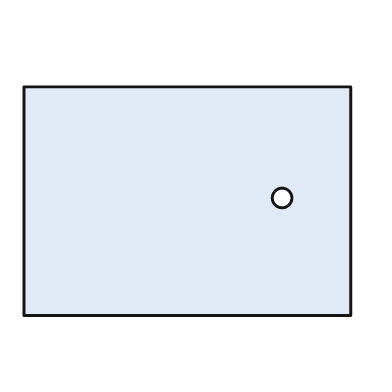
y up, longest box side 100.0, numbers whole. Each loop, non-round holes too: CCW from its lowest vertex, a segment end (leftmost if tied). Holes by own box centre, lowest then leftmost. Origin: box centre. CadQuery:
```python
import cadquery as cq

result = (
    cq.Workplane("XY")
    .moveTo(-50.0, -35.0)
    .lineTo(50.0, -35.0)
    .lineTo(50.0, 35.0)
    .lineTo(-50.0, 35.0)
    .close()
    .moveTo(29.0, 1.0)
    .circle(3.0)
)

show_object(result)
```